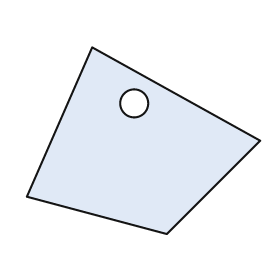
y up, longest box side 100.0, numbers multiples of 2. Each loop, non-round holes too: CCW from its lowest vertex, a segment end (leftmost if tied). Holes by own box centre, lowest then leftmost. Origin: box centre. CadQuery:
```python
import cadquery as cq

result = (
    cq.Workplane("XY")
    .moveTo(10.0, -40.0)
    .lineTo(50.0, 0.0)
    .lineTo(-22.0, 40.0)
    .lineTo(-50.0, -24.0)
    .close()
    .moveTo(-4.0, 16.0)
    .circle(6.0)
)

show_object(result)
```